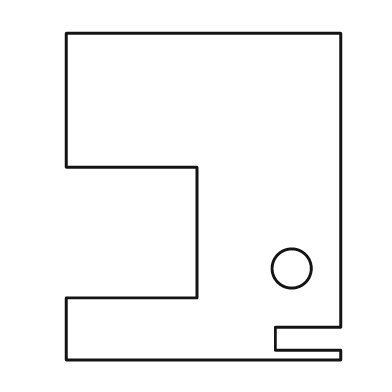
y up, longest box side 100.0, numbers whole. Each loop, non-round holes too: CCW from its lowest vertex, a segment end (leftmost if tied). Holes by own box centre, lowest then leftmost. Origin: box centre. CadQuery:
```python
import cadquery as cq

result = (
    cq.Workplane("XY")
    .moveTo(-42.0, -50.0)
    .lineTo(42.0, -50.0)
    .lineTo(42.0, -47.0)
    .lineTo(22.0, -47.0)
    .lineTo(22.0, -40.0)
    .lineTo(42.0, -40.0)
    .lineTo(42.0, 50.0)
    .lineTo(-42.0, 50.0)
    .lineTo(-42.0, 9.0)
    .lineTo(-2.0, 9.0)
    .lineTo(-2.0, -31.0)
    .lineTo(-42.0, -31.0)
    .close()
    .moveTo(27.0, -22.0)
    .circle(6.0)
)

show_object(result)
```